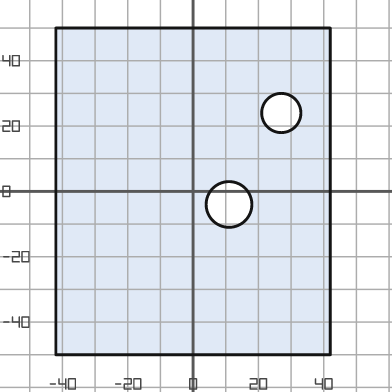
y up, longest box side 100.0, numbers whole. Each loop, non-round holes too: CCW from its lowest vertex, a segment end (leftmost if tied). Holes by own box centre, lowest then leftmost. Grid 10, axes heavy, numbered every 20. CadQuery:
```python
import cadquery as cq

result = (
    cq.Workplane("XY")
    .moveTo(-42.0, -50.0)
    .lineTo(42.0, -50.0)
    .lineTo(42.0, 50.0)
    .lineTo(-42.0, 50.0)
    .close()
    .moveTo(11.0, -4.0)
    .circle(7.0)
    .moveTo(27.0, 24.0)
    .circle(6.0)
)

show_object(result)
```